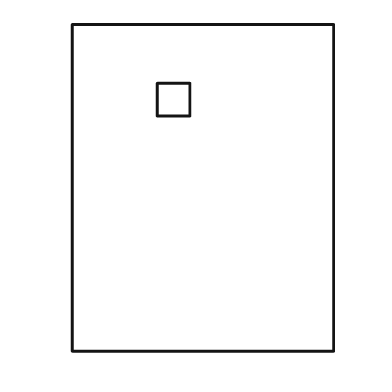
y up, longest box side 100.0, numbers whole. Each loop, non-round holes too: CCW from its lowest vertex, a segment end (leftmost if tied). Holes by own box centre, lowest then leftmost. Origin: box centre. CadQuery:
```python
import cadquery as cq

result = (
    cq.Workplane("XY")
    .moveTo(-40.0, -50.0)
    .lineTo(40.0, -50.0)
    .lineTo(40.0, 50.0)
    .lineTo(-40.0, 50.0)
    .close()
    .moveTo(-14.0, 22.0)
    .lineTo(-4.0, 22.0)
    .lineTo(-4.0, 32.0)
    .lineTo(-14.0, 32.0)
    .close()
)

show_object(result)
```